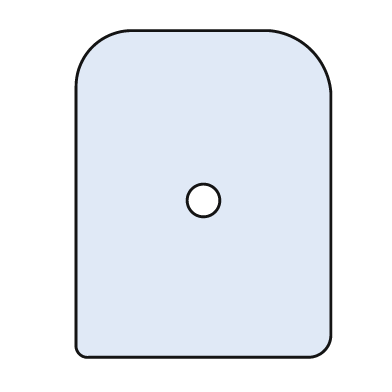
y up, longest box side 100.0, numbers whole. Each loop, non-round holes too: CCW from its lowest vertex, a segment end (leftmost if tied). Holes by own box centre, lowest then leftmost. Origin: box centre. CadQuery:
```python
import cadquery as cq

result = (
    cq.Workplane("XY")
    .moveTo(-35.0, -50.0)
    .lineTo(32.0, -50.0)
    .threePointArc((37.0, -48.0), (39.0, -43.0))
    .lineTo(39.0, 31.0)
    .threePointArc((33.0, 44.0), (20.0, 50.0))
    .lineTo(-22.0, 50.0)
    .threePointArc((-34.0, 45.0), (-39.0, 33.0))
    .lineTo(-39.0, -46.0)
    .threePointArc((-38.0, -49.0), (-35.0, -50.0))
    .close()
    .moveTo(0.0, -2.0)
    .circle(5.0)
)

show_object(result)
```